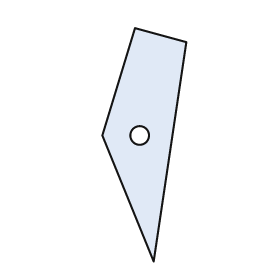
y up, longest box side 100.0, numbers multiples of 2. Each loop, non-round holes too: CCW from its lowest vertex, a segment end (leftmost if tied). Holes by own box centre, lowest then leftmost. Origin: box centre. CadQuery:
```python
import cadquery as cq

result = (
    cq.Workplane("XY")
    .moveTo(4.0, -50.0)
    .lineTo(18.0, 44.0)
    .lineTo(-4.0, 50.0)
    .lineTo(-18.0, 4.0)
    .close()
    .moveTo(-2.0, 4.0)
    .circle(4.0)
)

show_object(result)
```